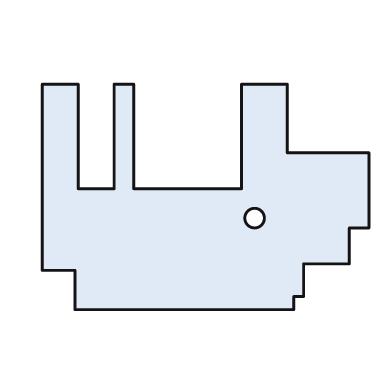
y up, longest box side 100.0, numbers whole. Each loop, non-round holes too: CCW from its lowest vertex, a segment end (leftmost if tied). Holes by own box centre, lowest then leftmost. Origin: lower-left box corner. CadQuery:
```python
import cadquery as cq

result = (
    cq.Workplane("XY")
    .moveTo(10.0, 0.0)
    .lineTo(77.0, 0.0)
    .lineTo(77.0, 4.0)
    .lineTo(80.0, 4.0)
    .lineTo(80.0, 14.0)
    .lineTo(94.0, 14.0)
    .lineTo(94.0, 25.0)
    .lineTo(100.0, 25.0)
    .lineTo(100.0, 48.0)
    .lineTo(75.0, 48.0)
    .lineTo(75.0, 69.0)
    .lineTo(61.0, 69.0)
    .lineTo(61.0, 37.0)
    .lineTo(28.0, 37.0)
    .lineTo(28.0, 69.0)
    .lineTo(22.0, 69.0)
    .lineTo(22.0, 37.0)
    .lineTo(11.0, 37.0)
    .lineTo(11.0, 69.0)
    .lineTo(0.0, 69.0)
    .lineTo(0.0, 12.0)
    .lineTo(10.0, 12.0)
    .close()
    .moveTo(65.0, 28.0)
    .circle(3.0)
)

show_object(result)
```